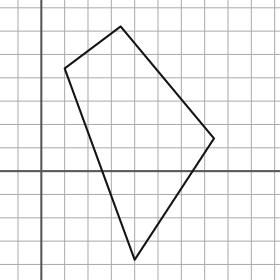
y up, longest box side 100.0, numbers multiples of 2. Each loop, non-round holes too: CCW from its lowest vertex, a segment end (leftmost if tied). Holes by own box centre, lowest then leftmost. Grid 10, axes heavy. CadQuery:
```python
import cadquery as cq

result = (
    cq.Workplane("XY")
    .moveTo(40.0, -38.0)
    .lineTo(74.0, 14.0)
    .lineTo(34.0, 62.0)
    .lineTo(10.0, 44.0)
    .close()
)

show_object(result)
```